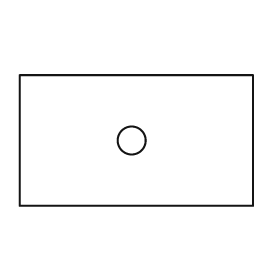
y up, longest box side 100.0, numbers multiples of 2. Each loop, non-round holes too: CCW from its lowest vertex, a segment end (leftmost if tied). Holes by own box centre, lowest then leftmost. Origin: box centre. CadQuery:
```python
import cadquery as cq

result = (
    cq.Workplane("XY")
    .moveTo(-50.0, -28.0)
    .lineTo(50.0, -28.0)
    .lineTo(50.0, 28.0)
    .lineTo(-50.0, 28.0)
    .close()
    .moveTo(-2.0, 0.0)
    .circle(6.0)
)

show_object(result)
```